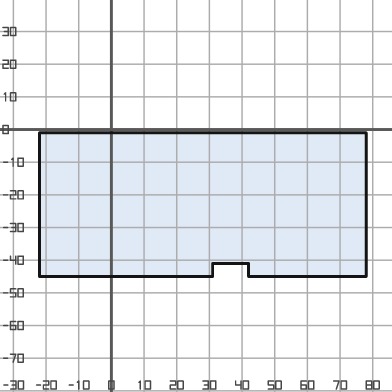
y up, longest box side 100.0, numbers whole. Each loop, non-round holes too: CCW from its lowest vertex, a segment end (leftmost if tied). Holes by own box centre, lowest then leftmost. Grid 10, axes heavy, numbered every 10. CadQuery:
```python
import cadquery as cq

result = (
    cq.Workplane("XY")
    .moveTo(-22.0, -45.0)
    .lineTo(31.0, -45.0)
    .lineTo(31.0, -41.0)
    .lineTo(42.0, -41.0)
    .lineTo(42.0, -45.0)
    .lineTo(78.0, -45.0)
    .lineTo(78.0, -1.0)
    .lineTo(-22.0, -1.0)
    .close()
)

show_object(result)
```